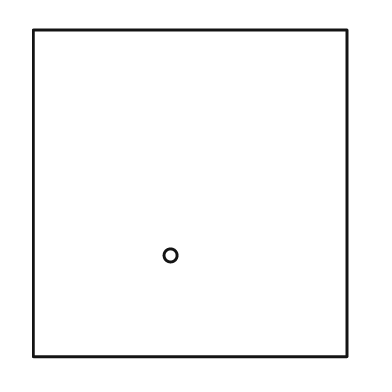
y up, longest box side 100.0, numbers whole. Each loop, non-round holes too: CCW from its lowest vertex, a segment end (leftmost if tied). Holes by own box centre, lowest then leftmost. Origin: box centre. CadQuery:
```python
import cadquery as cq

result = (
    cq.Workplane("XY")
    .moveTo(-48.0, -50.0)
    .lineTo(48.0, -50.0)
    .lineTo(48.0, 50.0)
    .lineTo(-48.0, 50.0)
    .close()
    .moveTo(-6.0, -19.0)
    .circle(2.0)
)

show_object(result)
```